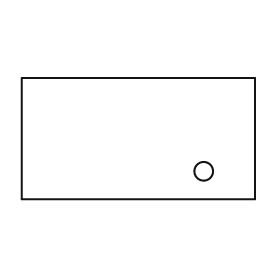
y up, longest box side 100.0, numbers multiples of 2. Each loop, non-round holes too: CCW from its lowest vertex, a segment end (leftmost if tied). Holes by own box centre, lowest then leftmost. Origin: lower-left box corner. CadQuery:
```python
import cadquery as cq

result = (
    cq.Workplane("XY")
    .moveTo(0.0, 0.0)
    .lineTo(100.0, 0.0)
    .lineTo(100.0, 52.0)
    .lineTo(0.0, 52.0)
    .close()
    .moveTo(78.0, 12.0)
    .circle(4.0)
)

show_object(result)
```